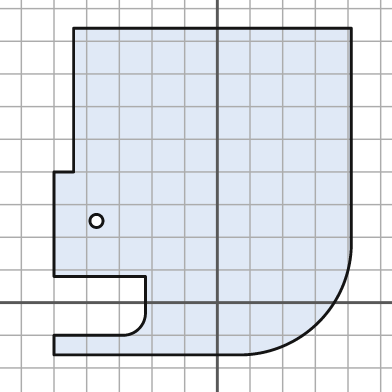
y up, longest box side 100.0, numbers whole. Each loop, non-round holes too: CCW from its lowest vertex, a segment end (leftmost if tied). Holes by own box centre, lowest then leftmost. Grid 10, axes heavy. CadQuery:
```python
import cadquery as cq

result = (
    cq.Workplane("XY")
    .moveTo(-50.0, -16.0)
    .lineTo(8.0, -16.0)
    .threePointArc((31.0, -6.0), (41.0, 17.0))
    .lineTo(41.0, 84.0)
    .lineTo(-44.0, 84.0)
    .lineTo(-44.0, 40.0)
    .lineTo(-50.0, 40.0)
    .lineTo(-50.0, 8.0)
    .lineTo(-22.0, 8.0)
    .lineTo(-22.0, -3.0)
    .threePointArc((-24.0, -8.0), (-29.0, -10.0))
    .lineTo(-50.0, -10.0)
    .close()
    .moveTo(-37.0, 25.0)
    .circle(2.0)
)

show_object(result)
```